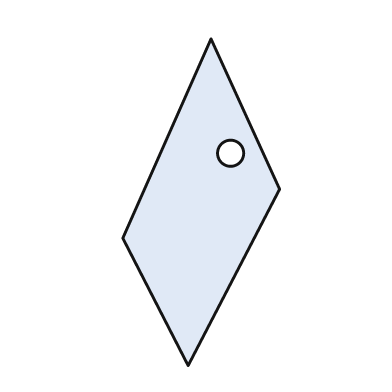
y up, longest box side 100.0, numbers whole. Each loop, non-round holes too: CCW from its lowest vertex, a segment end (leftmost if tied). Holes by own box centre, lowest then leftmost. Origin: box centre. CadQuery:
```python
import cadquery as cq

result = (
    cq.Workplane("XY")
    .moveTo(-4.0, -50.0)
    .lineTo(24.0, 4.0)
    .lineTo(3.0, 50.0)
    .lineTo(-24.0, -11.0)
    .close()
    .moveTo(9.0, 15.0)
    .circle(4.0)
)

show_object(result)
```